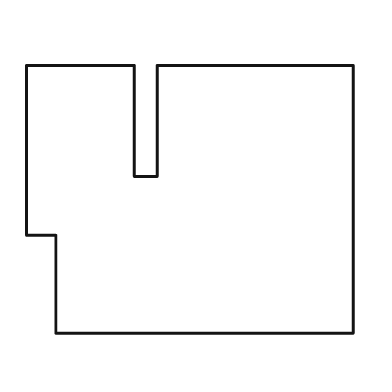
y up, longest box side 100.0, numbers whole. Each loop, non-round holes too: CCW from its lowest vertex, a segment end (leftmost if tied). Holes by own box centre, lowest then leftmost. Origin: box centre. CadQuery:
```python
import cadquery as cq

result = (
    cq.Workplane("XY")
    .moveTo(-41.0, -41.0)
    .lineTo(50.0, -41.0)
    .lineTo(50.0, 41.0)
    .lineTo(-10.0, 41.0)
    .lineTo(-10.0, 7.0)
    .lineTo(-17.0, 7.0)
    .lineTo(-17.0, 41.0)
    .lineTo(-50.0, 41.0)
    .lineTo(-50.0, -11.0)
    .lineTo(-41.0, -11.0)
    .close()
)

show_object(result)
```